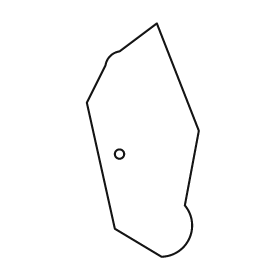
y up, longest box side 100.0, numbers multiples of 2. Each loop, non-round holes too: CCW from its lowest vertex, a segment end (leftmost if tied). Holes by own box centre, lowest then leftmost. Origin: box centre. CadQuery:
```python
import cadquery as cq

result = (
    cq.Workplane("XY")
    .moveTo(8.0, -50.0)
    .threePointArc((20.0, -42.0), (18.0, -28.0))
    .lineTo(24.0, 4.0)
    .lineTo(6.0, 50.0)
    .lineTo(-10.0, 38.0)
    .threePointArc((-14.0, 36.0), (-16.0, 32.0))
    .lineTo(-24.0, 16.0)
    .lineTo(-12.0, -38.0)
    .close()
    .moveTo(-10.0, -6.0)
    .circle(2.0)
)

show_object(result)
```